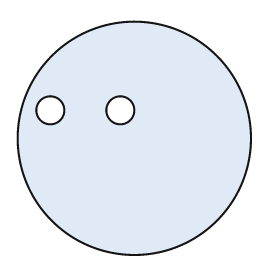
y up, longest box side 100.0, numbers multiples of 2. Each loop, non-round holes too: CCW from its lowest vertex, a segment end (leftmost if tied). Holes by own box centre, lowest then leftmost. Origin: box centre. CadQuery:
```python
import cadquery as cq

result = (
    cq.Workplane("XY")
    .moveTo(0.0, 0.0)
    .circle(50.0)
    .moveTo(-36.0, 12.0)
    .circle(6.0)
    .moveTo(-6.0, 12.0)
    .circle(6.0)
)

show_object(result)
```